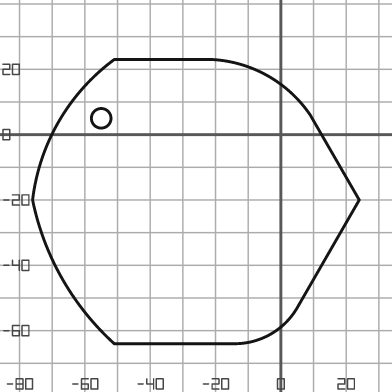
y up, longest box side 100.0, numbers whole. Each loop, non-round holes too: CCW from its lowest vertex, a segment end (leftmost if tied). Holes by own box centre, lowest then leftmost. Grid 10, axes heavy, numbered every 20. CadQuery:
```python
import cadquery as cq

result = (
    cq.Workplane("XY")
    .moveTo(-51.0, -64.0)
    .lineTo(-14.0, -64.0)
    .threePointArc((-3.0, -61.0), (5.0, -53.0))
    .lineTo(24.0, -20.0)
    .lineTo(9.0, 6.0)
    .threePointArc((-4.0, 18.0), (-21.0, 23.0))
    .lineTo(-51.0, 23.0)
    .threePointArc((-68.0, 4.0), (-76.0, -20.0))
    .threePointArc((-67.0, -44.0), (-51.0, -64.0))
    .close()
    .moveTo(-55.0, 5.0)
    .circle(3.0)
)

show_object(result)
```